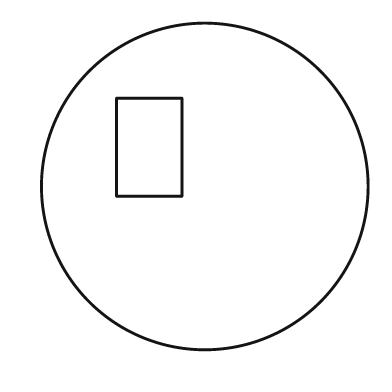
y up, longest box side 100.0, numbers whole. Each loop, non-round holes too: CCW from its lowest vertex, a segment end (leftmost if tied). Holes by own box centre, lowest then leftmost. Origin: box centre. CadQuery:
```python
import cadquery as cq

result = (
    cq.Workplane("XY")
    .moveTo(0.0, 0.0)
    .circle(50.0)
    .moveTo(-27.0, -3.0)
    .lineTo(-7.0, -3.0)
    .lineTo(-7.0, 27.0)
    .lineTo(-27.0, 27.0)
    .close()
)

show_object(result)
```